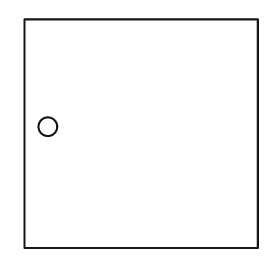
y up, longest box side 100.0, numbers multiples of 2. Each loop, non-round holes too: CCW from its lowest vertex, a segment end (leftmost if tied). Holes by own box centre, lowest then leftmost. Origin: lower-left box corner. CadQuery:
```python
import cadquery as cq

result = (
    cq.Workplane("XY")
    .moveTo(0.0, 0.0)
    .lineTo(100.0, 0.0)
    .lineTo(100.0, 98.0)
    .lineTo(0.0, 98.0)
    .close()
    .moveTo(10.0, 52.0)
    .circle(4.0)
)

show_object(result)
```